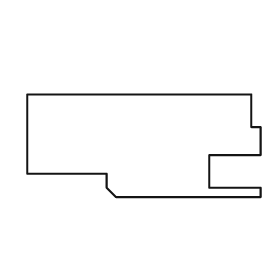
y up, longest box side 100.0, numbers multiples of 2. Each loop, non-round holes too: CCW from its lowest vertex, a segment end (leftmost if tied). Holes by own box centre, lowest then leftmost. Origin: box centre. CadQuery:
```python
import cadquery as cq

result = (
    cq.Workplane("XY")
    .moveTo(-12.0, -22.0)
    .lineTo(50.0, -22.0)
    .lineTo(50.0, -18.0)
    .lineTo(28.0, -18.0)
    .lineTo(28.0, -4.0)
    .lineTo(50.0, -4.0)
    .lineTo(50.0, 8.0)
    .lineTo(46.0, 8.0)
    .lineTo(46.0, 22.0)
    .lineTo(-50.0, 22.0)
    .lineTo(-50.0, -12.0)
    .lineTo(-16.0, -12.0)
    .lineTo(-16.0, -18.0)
    .close()
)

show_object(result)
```